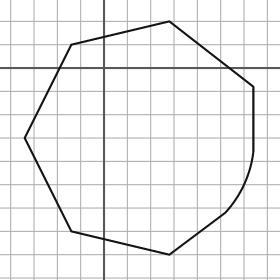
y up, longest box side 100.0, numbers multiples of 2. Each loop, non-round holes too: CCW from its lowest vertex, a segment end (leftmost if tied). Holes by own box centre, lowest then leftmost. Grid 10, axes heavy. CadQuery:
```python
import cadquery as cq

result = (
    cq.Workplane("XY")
    .moveTo(28.0, -80.0)
    .lineTo(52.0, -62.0)
    .threePointArc((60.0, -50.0), (64.0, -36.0))
    .lineTo(64.0, -8.0)
    .lineTo(28.0, 20.0)
    .lineTo(-14.0, 10.0)
    .lineTo(-34.0, -30.0)
    .lineTo(-14.0, -70.0)
    .close()
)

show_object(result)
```